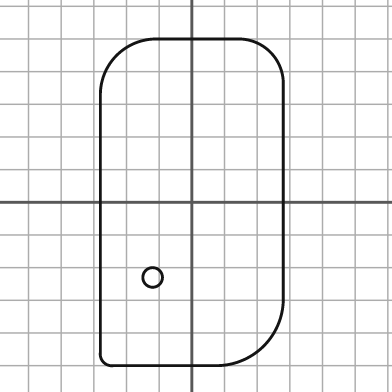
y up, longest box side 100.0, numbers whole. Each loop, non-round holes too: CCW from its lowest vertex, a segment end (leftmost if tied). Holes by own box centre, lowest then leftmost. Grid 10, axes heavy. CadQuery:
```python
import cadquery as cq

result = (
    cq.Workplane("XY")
    .moveTo(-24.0, -50.0)
    .lineTo(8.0, -50.0)
    .threePointArc((22.0, -44.0), (28.0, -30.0))
    .lineTo(28.0, 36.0)
    .threePointArc((24.0, 46.0), (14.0, 50.0))
    .lineTo(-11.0, 50.0)
    .threePointArc((-23.0, 45.0), (-28.0, 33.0))
    .lineTo(-28.0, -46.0)
    .threePointArc((-27.0, -49.0), (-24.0, -50.0))
    .close()
    .moveTo(-12.0, -23.0)
    .circle(3.0)
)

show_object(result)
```